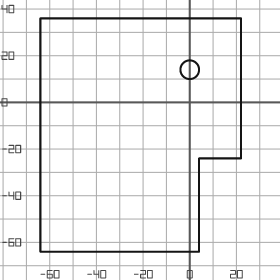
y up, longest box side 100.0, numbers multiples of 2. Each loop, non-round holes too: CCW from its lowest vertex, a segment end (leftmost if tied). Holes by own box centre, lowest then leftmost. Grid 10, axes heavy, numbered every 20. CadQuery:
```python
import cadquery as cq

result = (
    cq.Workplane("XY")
    .moveTo(-64.0, -64.0)
    .lineTo(4.0, -64.0)
    .lineTo(4.0, -24.0)
    .lineTo(22.0, -24.0)
    .lineTo(22.0, 36.0)
    .lineTo(-64.0, 36.0)
    .close()
    .moveTo(0.0, 14.0)
    .circle(4.0)
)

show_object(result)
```